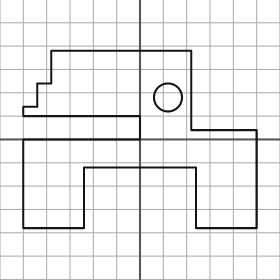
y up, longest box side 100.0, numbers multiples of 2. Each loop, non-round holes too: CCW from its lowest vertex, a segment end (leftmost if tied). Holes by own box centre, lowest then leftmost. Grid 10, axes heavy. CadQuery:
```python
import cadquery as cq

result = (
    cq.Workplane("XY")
    .moveTo(-50.0, -38.0)
    .lineTo(-24.0, -38.0)
    .lineTo(-24.0, -12.0)
    .lineTo(24.0, -12.0)
    .lineTo(24.0, -38.0)
    .lineTo(50.0, -38.0)
    .lineTo(50.0, 4.0)
    .lineTo(22.0, 4.0)
    .lineTo(22.0, 38.0)
    .lineTo(-38.0, 38.0)
    .lineTo(-38.0, 24.0)
    .lineTo(-44.0, 24.0)
    .lineTo(-44.0, 14.0)
    .lineTo(-50.0, 14.0)
    .lineTo(-50.0, 10.0)
    .lineTo(0.0, 10.0)
    .lineTo(0.0, 0.0)
    .lineTo(-50.0, 0.0)
    .close()
    .moveTo(12.0, 18.0)
    .circle(6.0)
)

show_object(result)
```